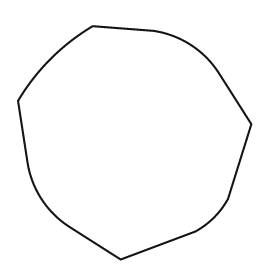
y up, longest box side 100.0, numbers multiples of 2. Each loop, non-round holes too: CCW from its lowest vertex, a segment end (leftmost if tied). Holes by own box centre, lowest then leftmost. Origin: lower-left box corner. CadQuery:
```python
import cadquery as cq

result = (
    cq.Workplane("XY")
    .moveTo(44.0, 0.0)
    .lineTo(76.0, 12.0)
    .threePointArc((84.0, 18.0), (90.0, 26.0))
    .lineTo(100.0, 58.0)
    .lineTo(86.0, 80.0)
    .threePointArc((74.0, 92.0), (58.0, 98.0))
    .lineTo(32.0, 100.0)
    .threePointArc((14.0, 86.0), (0.0, 68.0))
    .lineTo(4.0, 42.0)
    .threePointArc((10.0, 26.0), (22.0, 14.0))
    .close()
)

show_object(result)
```